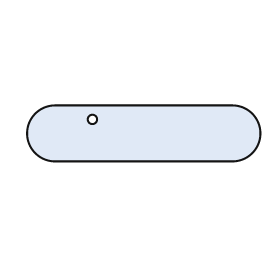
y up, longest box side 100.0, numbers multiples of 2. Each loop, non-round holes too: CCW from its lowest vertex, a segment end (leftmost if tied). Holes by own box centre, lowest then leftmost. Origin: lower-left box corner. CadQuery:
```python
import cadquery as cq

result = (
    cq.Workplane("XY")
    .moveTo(12.0, 0.0)
    .lineTo(88.0, 0.0)
    .threePointArc((100.0, 12.0), (88.0, 24.0))
    .lineTo(12.0, 24.0)
    .threePointArc((0.0, 12.0), (12.0, 0.0))
    .close()
    .moveTo(28.0, 18.0)
    .circle(2.0)
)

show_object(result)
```